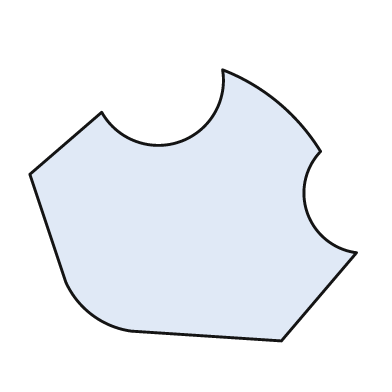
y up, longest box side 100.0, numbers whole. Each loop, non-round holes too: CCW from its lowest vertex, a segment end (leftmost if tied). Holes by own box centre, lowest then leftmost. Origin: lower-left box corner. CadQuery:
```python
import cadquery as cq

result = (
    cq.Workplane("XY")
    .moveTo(77.0, 0.0)
    .lineTo(100.0, 27.0)
    .threePointArc((85.0, 39.0), (89.0, 58.0))
    .threePointArc((76.0, 73.0), (59.0, 83.0))
    .threePointArc((46.0, 61.0), (22.0, 70.0))
    .lineTo(0.0, 51.0)
    .lineTo(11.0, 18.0)
    .threePointArc((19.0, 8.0), (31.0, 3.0))
    .close()
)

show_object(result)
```